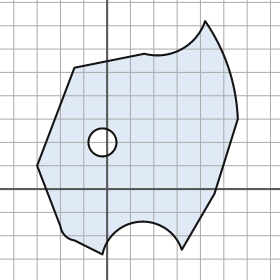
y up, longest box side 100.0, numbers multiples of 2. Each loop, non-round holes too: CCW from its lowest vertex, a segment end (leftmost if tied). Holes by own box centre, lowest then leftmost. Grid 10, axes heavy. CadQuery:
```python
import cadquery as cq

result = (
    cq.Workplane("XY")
    .moveTo(-2.0, -28.0)
    .threePointArc((14.0, -14.0), (32.0, -26.0))
    .lineTo(46.0, -2.0)
    .lineTo(56.0, 30.0)
    .threePointArc((52.0, 52.0), (42.0, 72.0))
    .threePointArc((32.0, 60.0), (16.0, 58.0))
    .lineTo(-14.0, 52.0)
    .lineTo(-30.0, 10.0)
    .lineTo(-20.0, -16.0)
    .threePointArc((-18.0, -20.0), (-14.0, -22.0))
    .close()
    .moveTo(-2.0, 20.0)
    .circle(6.0)
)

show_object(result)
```